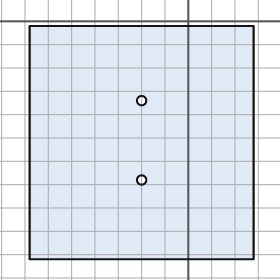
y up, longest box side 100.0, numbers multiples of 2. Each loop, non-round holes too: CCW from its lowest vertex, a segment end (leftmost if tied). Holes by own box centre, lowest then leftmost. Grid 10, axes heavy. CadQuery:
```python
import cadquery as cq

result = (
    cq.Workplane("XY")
    .moveTo(-68.0, -102.0)
    .lineTo(28.0, -102.0)
    .lineTo(28.0, -2.0)
    .lineTo(-68.0, -2.0)
    .close()
    .moveTo(-20.0, -68.0)
    .circle(2.0)
    .moveTo(-20.0, -34.0)
    .circle(2.0)
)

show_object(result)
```